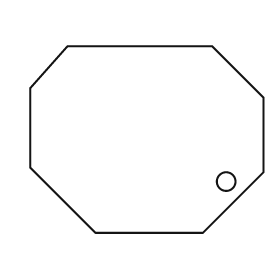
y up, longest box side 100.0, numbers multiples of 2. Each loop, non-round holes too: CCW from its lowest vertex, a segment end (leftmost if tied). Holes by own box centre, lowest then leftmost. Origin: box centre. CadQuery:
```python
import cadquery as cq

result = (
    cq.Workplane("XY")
    .moveTo(-22.0, -40.0)
    .lineTo(24.0, -40.0)
    .lineTo(50.0, -14.0)
    .lineTo(50.0, 18.0)
    .lineTo(28.0, 40.0)
    .lineTo(-34.0, 40.0)
    .lineTo(-50.0, 22.0)
    .lineTo(-50.0, -12.0)
    .close()
    .moveTo(34.0, -18.0)
    .circle(4.0)
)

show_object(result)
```